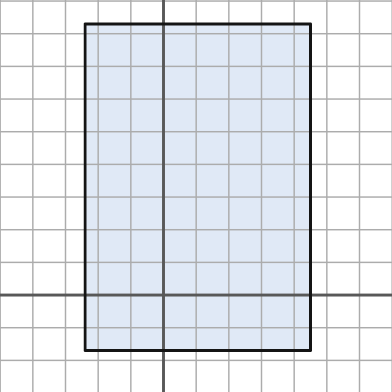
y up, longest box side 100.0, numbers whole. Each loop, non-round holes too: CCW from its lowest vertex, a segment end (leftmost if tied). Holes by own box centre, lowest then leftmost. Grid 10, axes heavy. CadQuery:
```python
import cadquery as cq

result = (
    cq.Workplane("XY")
    .moveTo(-24.0, -17.0)
    .lineTo(45.0, -17.0)
    .lineTo(45.0, 83.0)
    .lineTo(-24.0, 83.0)
    .close()
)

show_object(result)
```